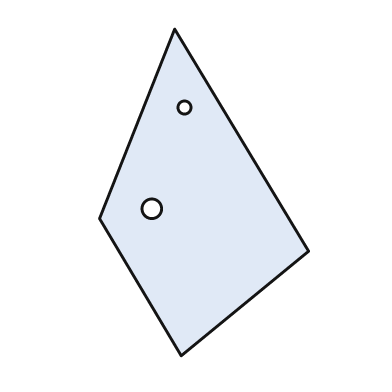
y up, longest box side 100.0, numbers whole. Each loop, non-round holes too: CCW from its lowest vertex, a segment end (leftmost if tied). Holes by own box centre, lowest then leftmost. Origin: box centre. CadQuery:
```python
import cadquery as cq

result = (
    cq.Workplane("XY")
    .moveTo(-7.0, -50.0)
    .lineTo(32.0, -18.0)
    .lineTo(-9.0, 50.0)
    .lineTo(-32.0, -8.0)
    .close()
    .moveTo(-16.0, -5.0)
    .circle(3.0)
    .moveTo(-6.0, 26.0)
    .circle(2.0)
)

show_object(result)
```